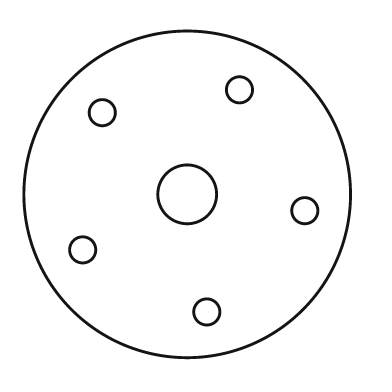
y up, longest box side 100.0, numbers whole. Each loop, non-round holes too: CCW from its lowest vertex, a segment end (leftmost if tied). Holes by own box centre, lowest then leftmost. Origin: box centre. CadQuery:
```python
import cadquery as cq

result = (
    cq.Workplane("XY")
    .moveTo(0.0, 0.0)
    .circle(50.0)
    .moveTo(6.0, -36.0)
    .circle(4.0)
    .moveTo(-32.0, -17.0)
    .circle(4.0)
    .moveTo(36.0, -5.0)
    .circle(4.0)
    .moveTo(0.0, 0.0)
    .circle(9.0)
    .moveTo(-26.0, 25.0)
    .circle(4.0)
    .moveTo(16.0, 32.0)
    .circle(4.0)
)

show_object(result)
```